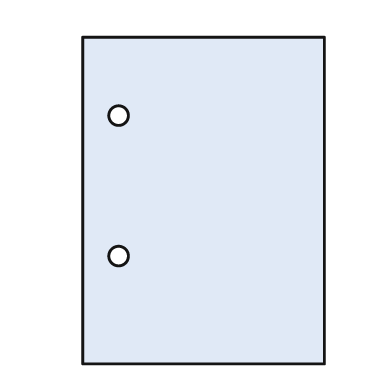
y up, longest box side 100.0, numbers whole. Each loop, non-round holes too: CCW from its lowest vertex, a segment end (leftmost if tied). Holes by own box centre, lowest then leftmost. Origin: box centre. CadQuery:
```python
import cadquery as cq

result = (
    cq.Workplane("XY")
    .moveTo(-37.0, -50.0)
    .lineTo(37.0, -50.0)
    .lineTo(37.0, 50.0)
    .lineTo(-37.0, 50.0)
    .close()
    .moveTo(-26.0, -17.0)
    .circle(3.0)
    .moveTo(-26.0, 26.0)
    .circle(3.0)
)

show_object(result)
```